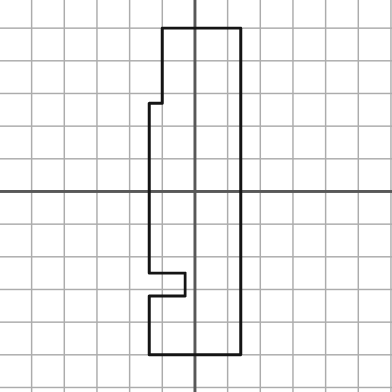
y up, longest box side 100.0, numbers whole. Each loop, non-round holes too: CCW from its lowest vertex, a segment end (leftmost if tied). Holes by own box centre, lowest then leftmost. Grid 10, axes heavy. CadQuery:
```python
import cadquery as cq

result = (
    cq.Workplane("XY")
    .moveTo(-14.0, -50.0)
    .lineTo(14.0, -50.0)
    .lineTo(14.0, 50.0)
    .lineTo(-10.0, 50.0)
    .lineTo(-10.0, 27.0)
    .lineTo(-14.0, 27.0)
    .lineTo(-14.0, -25.0)
    .lineTo(-3.0, -25.0)
    .lineTo(-3.0, -32.0)
    .lineTo(-14.0, -32.0)
    .close()
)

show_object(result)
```